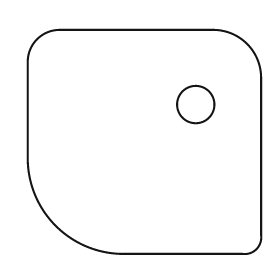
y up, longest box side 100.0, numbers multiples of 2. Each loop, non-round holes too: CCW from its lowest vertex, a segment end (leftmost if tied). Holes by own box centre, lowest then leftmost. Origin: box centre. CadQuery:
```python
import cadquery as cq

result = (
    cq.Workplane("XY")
    .moveTo(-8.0, -48.0)
    .lineTo(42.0, -48.0)
    .threePointArc((48.0, -46.0), (50.0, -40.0))
    .lineTo(50.0, 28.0)
    .threePointArc((44.0, 42.0), (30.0, 48.0))
    .lineTo(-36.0, 48.0)
    .threePointArc((-46.0, 44.0), (-50.0, 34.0))
    .lineTo(-50.0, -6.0)
    .threePointArc((-38.0, -36.0), (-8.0, -48.0))
    .close()
    .moveTo(22.0, 16.0)
    .circle(8.0)
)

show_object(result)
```